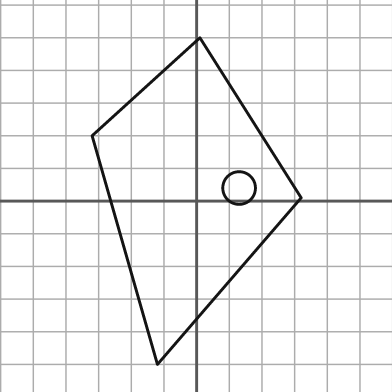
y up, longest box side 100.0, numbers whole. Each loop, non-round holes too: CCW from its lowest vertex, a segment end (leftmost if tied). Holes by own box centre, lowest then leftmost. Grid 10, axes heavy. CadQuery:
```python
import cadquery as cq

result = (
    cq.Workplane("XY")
    .moveTo(-12.0, -50.0)
    .lineTo(32.0, 1.0)
    .lineTo(1.0, 50.0)
    .lineTo(-32.0, 20.0)
    .close()
    .moveTo(13.0, 4.0)
    .circle(5.0)
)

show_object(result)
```